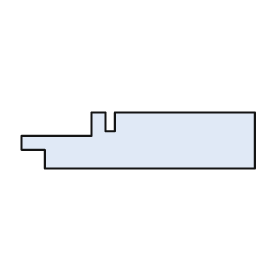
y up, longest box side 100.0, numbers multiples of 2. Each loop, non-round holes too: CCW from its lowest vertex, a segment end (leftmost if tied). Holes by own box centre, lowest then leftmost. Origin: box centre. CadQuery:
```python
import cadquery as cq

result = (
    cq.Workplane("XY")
    .moveTo(-40.0, -12.0)
    .lineTo(50.0, -12.0)
    .lineTo(50.0, 12.0)
    .lineTo(-10.0, 12.0)
    .lineTo(-10.0, 4.0)
    .lineTo(-14.0, 4.0)
    .lineTo(-14.0, 12.0)
    .lineTo(-20.0, 12.0)
    .lineTo(-20.0, 2.0)
    .lineTo(-50.0, 2.0)
    .lineTo(-50.0, -4.0)
    .lineTo(-40.0, -4.0)
    .close()
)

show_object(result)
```